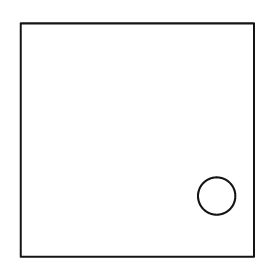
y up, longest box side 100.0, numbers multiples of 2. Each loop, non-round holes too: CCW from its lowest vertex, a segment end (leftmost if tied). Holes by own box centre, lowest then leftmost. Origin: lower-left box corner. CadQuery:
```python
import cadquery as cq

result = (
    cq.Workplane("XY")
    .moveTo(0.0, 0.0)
    .lineTo(100.0, 0.0)
    .lineTo(100.0, 100.0)
    .lineTo(0.0, 100.0)
    .close()
    .moveTo(84.0, 26.0)
    .circle(8.0)
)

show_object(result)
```